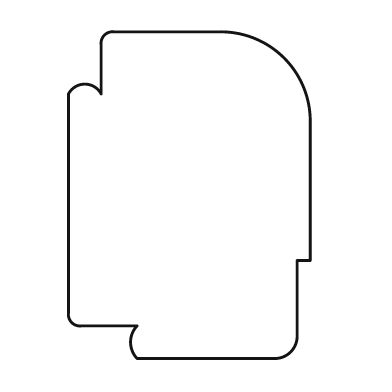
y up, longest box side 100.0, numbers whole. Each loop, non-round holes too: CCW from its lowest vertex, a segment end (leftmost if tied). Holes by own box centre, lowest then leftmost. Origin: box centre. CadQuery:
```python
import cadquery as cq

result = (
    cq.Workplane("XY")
    .moveTo(-16.0, -50.0)
    .lineTo(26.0, -50.0)
    .threePointArc((31.0, -48.0), (33.0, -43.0))
    .lineTo(33.0, -20.0)
    .lineTo(37.0, -20.0)
    .lineTo(37.0, 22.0)
    .threePointArc((29.0, 42.0), (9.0, 50.0))
    .lineTo(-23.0, 50.0)
    .threePointArc((-26.0, 49.0), (-27.0, 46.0))
    .lineTo(-27.0, 31.0)
    .threePointArc((-32.0, 34.0), (-37.0, 31.0))
    .lineTo(-37.0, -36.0)
    .threePointArc((-36.0, -39.0), (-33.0, -40.0))
    .lineTo(-16.0, -40.0)
    .threePointArc((-18.0, -45.0), (-16.0, -50.0))
    .close()
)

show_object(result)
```